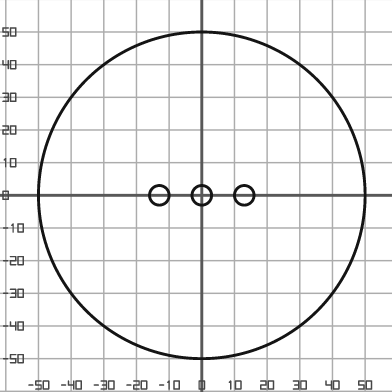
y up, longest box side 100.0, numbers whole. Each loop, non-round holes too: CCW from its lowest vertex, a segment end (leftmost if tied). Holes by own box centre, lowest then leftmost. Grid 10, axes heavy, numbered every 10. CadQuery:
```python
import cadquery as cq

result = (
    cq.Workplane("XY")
    .moveTo(0.0, 0.0)
    .circle(50.0)
    .moveTo(-13.0, 0.0)
    .circle(3.0)
    .moveTo(0.0, 0.0)
    .circle(3.0)
    .moveTo(13.0, 0.0)
    .circle(3.0)
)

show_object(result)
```